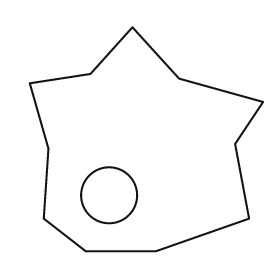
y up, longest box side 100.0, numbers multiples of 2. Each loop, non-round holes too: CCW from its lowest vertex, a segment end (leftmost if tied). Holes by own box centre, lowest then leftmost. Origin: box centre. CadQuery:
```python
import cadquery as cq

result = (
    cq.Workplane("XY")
    .moveTo(-26.0, -48.0)
    .lineTo(4.0, -48.0)
    .lineTo(44.0, -34.0)
    .lineTo(38.0, -2.0)
    .lineTo(50.0, 16.0)
    .lineTo(14.0, 26.0)
    .lineTo(-6.0, 48.0)
    .lineTo(-24.0, 28.0)
    .lineTo(-50.0, 24.0)
    .lineTo(-42.0, -4.0)
    .lineTo(-44.0, -34.0)
    .close()
    .moveTo(-16.0, -24.0)
    .circle(12.0)
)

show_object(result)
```